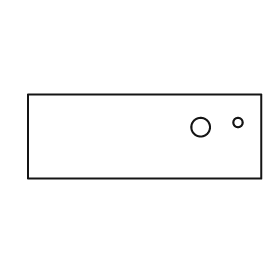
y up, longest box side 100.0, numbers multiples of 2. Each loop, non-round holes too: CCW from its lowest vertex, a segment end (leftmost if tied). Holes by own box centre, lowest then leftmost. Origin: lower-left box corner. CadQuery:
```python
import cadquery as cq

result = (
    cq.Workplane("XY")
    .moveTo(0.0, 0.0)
    .lineTo(100.0, 0.0)
    .lineTo(100.0, 36.0)
    .lineTo(0.0, 36.0)
    .close()
    .moveTo(74.0, 22.0)
    .circle(4.0)
    .moveTo(90.0, 24.0)
    .circle(2.0)
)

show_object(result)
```